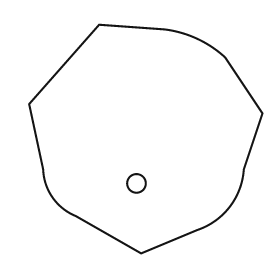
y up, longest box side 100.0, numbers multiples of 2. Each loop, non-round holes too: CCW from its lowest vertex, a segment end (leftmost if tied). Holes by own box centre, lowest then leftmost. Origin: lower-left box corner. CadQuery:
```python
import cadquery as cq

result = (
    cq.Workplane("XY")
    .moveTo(48.0, 0.0)
    .lineTo(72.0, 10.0)
    .threePointArc((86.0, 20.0), (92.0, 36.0))
    .lineTo(100.0, 60.0)
    .lineTo(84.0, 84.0)
    .threePointArc((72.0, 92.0), (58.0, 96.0))
    .lineTo(30.0, 98.0)
    .lineTo(0.0, 64.0)
    .lineTo(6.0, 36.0)
    .threePointArc((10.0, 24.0), (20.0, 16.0))
    .close()
    .moveTo(46.0, 30.0)
    .circle(4.0)
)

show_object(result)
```